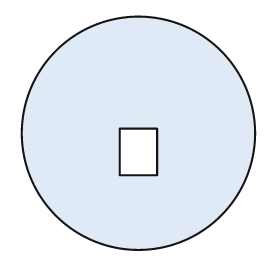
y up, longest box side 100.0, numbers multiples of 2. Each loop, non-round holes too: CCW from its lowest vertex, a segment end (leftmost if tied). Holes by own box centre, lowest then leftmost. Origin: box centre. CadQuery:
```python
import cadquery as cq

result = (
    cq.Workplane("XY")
    .moveTo(0.0, 0.0)
    .circle(50.0)
    .moveTo(-8.0, -18.0)
    .lineTo(8.0, -18.0)
    .lineTo(8.0, 2.0)
    .lineTo(-8.0, 2.0)
    .close()
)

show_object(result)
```